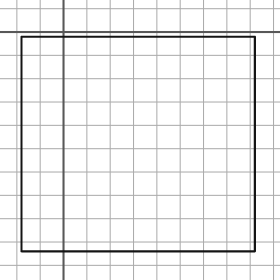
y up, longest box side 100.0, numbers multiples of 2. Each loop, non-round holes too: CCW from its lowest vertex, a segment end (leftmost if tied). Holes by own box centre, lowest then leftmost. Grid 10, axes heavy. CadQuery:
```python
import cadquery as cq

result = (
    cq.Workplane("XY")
    .moveTo(-18.0, -94.0)
    .lineTo(82.0, -94.0)
    .lineTo(82.0, -2.0)
    .lineTo(-18.0, -2.0)
    .close()
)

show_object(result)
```